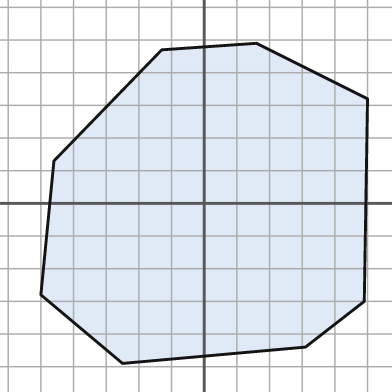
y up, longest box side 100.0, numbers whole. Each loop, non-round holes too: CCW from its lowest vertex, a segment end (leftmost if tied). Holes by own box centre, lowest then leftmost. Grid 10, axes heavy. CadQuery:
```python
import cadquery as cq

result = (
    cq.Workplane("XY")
    .moveTo(-25.0, -49.0)
    .lineTo(31.0, -44.0)
    .lineTo(49.0, -30.0)
    .lineTo(50.0, 32.0)
    .lineTo(16.0, 49.0)
    .lineTo(-13.0, 47.0)
    .lineTo(-46.0, 13.0)
    .lineTo(-50.0, -28.0)
    .close()
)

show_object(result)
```